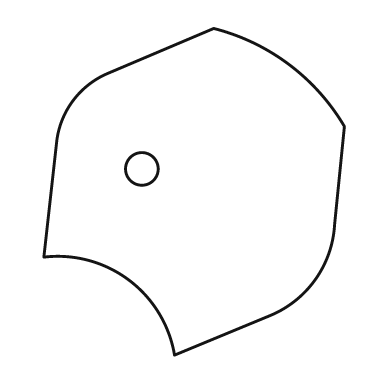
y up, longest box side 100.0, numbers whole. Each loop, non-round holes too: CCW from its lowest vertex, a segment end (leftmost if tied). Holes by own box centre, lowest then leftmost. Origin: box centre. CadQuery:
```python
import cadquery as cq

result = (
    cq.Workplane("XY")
    .moveTo(-6.0, -50.0)
    .lineTo(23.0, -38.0)
    .threePointArc((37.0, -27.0), (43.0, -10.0))
    .lineTo(46.0, 20.0)
    .threePointArc((29.0, 39.0), (6.0, 50.0))
    .lineTo(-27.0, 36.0)
    .threePointArc((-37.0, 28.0), (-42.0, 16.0))
    .lineTo(-46.0, -20.0)
    .threePointArc((-20.0, -27.0), (-6.0, -50.0))
    .close()
    .moveTo(-16.0, 7.0)
    .circle(5.0)
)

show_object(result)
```